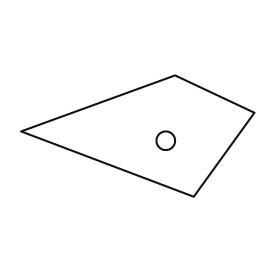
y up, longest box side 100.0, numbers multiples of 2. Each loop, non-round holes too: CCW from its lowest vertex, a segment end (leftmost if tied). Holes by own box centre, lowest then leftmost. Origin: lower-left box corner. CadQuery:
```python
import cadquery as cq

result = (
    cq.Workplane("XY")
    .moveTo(74.0, 0.0)
    .lineTo(100.0, 36.0)
    .lineTo(66.0, 52.0)
    .lineTo(0.0, 28.0)
    .close()
    .moveTo(62.0, 24.0)
    .circle(4.0)
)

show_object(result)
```